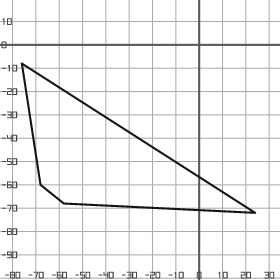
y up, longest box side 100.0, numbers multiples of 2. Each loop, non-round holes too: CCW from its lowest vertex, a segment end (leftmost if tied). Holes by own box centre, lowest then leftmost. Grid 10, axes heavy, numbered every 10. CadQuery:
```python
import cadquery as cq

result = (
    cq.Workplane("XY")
    .moveTo(24.0, -72.0)
    .lineTo(-76.0, -8.0)
    .lineTo(-68.0, -60.0)
    .lineTo(-58.0, -68.0)
    .close()
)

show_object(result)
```